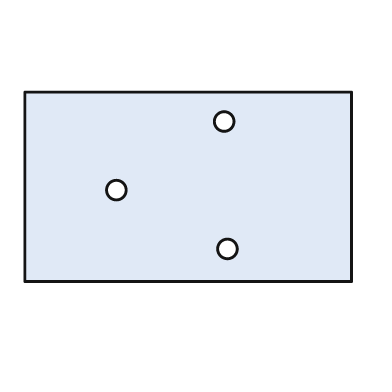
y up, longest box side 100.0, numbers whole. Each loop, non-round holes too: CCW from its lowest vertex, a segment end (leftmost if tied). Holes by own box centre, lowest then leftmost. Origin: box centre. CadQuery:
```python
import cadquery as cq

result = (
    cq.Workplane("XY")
    .moveTo(-50.0, -29.0)
    .lineTo(50.0, -29.0)
    .lineTo(50.0, 29.0)
    .lineTo(-50.0, 29.0)
    .close()
    .moveTo(12.0, -19.0)
    .circle(3.0)
    .moveTo(-22.0, -1.0)
    .circle(3.0)
    .moveTo(11.0, 20.0)
    .circle(3.0)
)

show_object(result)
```